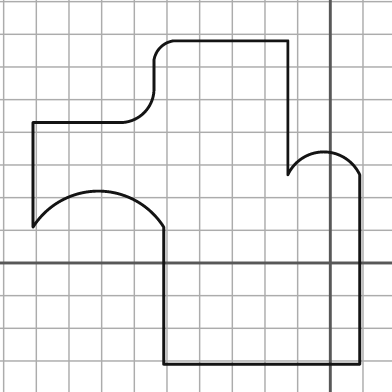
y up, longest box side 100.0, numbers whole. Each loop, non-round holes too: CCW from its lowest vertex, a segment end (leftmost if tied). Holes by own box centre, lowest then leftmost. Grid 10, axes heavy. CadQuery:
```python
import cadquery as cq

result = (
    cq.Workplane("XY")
    .moveTo(-51.0, -31.0)
    .lineTo(9.0, -31.0)
    .lineTo(9.0, 27.0)
    .threePointArc((-2.0, 34.0), (-13.0, 27.0))
    .lineTo(-13.0, 68.0)
    .lineTo(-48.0, 68.0)
    .threePointArc((-52.0, 66.0), (-54.0, 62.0))
    .lineTo(-54.0, 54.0)
    .threePointArc((-57.0, 46.0), (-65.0, 43.0))
    .lineTo(-91.0, 43.0)
    .lineTo(-91.0, 11.0)
    .threePointArc((-71.0, 22.0), (-51.0, 11.0))
    .close()
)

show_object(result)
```